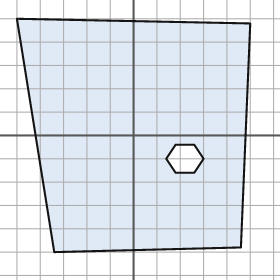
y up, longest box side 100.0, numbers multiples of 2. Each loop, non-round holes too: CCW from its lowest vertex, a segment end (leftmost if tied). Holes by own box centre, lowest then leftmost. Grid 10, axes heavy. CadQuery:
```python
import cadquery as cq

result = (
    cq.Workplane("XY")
    .moveTo(-34.0, -50.0)
    .lineTo(46.0, -48.0)
    .lineTo(50.0, 48.0)
    .lineTo(-50.0, 50.0)
    .close()
    .moveTo(18.0, -16.0)
    .lineTo(26.0, -16.0)
    .lineTo(30.0, -10.0)
    .lineTo(26.0, -4.0)
    .lineTo(18.0, -4.0)
    .lineTo(14.0, -10.0)
    .close()
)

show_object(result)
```